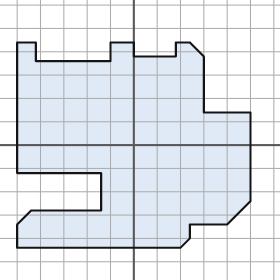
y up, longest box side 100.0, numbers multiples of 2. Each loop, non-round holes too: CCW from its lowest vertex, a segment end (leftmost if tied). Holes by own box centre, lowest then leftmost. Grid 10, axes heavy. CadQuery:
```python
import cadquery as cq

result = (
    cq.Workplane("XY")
    .moveTo(-50.0, -44.0)
    .lineTo(20.0, -44.0)
    .lineTo(24.0, -40.0)
    .lineTo(24.0, -34.0)
    .lineTo(40.0, -34.0)
    .lineTo(50.0, -24.0)
    .lineTo(50.0, 14.0)
    .lineTo(30.0, 14.0)
    .lineTo(30.0, 38.0)
    .lineTo(24.0, 44.0)
    .lineTo(18.0, 44.0)
    .lineTo(18.0, 38.0)
    .lineTo(0.0, 38.0)
    .lineTo(0.0, 44.0)
    .lineTo(-10.0, 44.0)
    .lineTo(-10.0, 36.0)
    .lineTo(-42.0, 36.0)
    .lineTo(-42.0, 44.0)
    .lineTo(-50.0, 44.0)
    .lineTo(-50.0, -12.0)
    .lineTo(-14.0, -12.0)
    .lineTo(-14.0, -28.0)
    .lineTo(-44.0, -28.0)
    .lineTo(-50.0, -34.0)
    .close()
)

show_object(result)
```